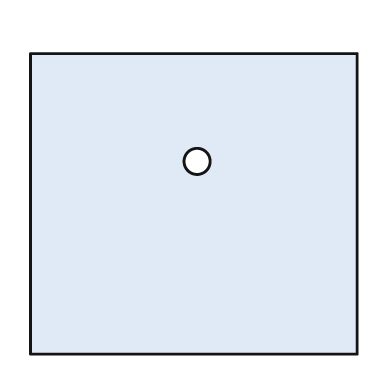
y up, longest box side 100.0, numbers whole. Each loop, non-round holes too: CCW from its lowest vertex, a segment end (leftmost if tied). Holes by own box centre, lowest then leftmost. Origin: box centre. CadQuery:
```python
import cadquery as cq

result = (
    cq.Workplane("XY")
    .moveTo(-50.0, -46.0)
    .lineTo(50.0, -46.0)
    .lineTo(50.0, 46.0)
    .lineTo(-50.0, 46.0)
    .close()
    .moveTo(1.0, 13.0)
    .circle(4.0)
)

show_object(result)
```